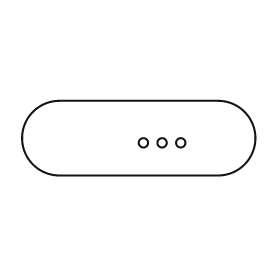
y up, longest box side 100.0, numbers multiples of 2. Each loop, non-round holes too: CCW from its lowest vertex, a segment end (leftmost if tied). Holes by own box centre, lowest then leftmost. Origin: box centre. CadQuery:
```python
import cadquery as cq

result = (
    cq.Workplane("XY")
    .moveTo(-34.0, -16.0)
    .lineTo(34.0, -16.0)
    .threePointArc((50.0, 0.0), (34.0, 16.0))
    .lineTo(-34.0, 16.0)
    .threePointArc((-50.0, 0.0), (-34.0, -16.0))
    .close()
    .moveTo(2.0, -2.0)
    .circle(2.0)
    .moveTo(10.0, -2.0)
    .circle(2.0)
    .moveTo(18.0, -2.0)
    .circle(2.0)
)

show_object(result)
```